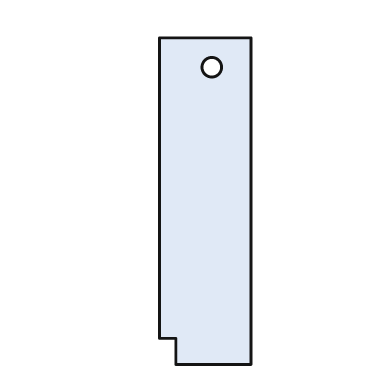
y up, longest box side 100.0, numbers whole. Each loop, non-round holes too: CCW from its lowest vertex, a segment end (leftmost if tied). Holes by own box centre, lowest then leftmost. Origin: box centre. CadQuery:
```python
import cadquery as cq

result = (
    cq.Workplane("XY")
    .moveTo(-9.0, -50.0)
    .lineTo(14.0, -50.0)
    .lineTo(14.0, 50.0)
    .lineTo(-14.0, 50.0)
    .lineTo(-14.0, -42.0)
    .lineTo(-9.0, -42.0)
    .close()
    .moveTo(2.0, 41.0)
    .circle(3.0)
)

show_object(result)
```